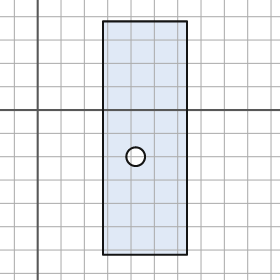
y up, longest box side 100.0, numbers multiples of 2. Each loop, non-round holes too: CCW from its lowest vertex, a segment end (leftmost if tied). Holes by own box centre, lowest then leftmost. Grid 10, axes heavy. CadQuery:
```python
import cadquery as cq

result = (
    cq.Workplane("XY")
    .moveTo(28.0, -62.0)
    .lineTo(64.0, -62.0)
    .lineTo(64.0, 38.0)
    .lineTo(28.0, 38.0)
    .close()
    .moveTo(42.0, -20.0)
    .circle(4.0)
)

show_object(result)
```